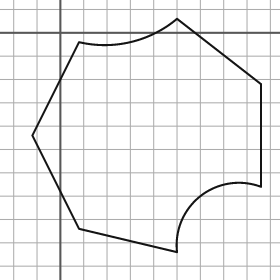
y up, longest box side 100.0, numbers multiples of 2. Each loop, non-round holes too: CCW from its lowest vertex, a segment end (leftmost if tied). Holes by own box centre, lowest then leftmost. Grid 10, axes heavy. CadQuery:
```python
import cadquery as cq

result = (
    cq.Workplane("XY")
    .moveTo(50.0, -94.0)
    .threePointArc((60.0, -70.0), (86.0, -66.0))
    .lineTo(86.0, -22.0)
    .lineTo(50.0, 6.0)
    .threePointArc((30.0, -4.0), (8.0, -4.0))
    .lineTo(-12.0, -44.0)
    .lineTo(8.0, -84.0)
    .close()
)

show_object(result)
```